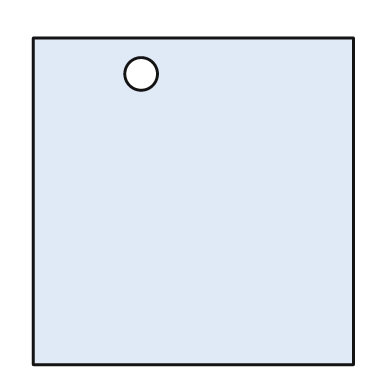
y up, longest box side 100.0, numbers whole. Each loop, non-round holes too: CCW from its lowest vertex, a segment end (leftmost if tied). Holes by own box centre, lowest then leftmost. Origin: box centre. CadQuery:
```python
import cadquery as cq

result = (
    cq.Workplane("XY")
    .moveTo(-49.0, -50.0)
    .lineTo(49.0, -50.0)
    .lineTo(49.0, 50.0)
    .lineTo(-49.0, 50.0)
    .close()
    .moveTo(-16.0, 39.0)
    .circle(5.0)
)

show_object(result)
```